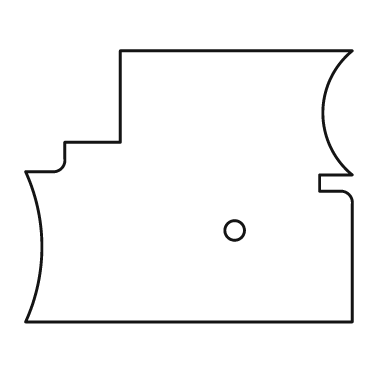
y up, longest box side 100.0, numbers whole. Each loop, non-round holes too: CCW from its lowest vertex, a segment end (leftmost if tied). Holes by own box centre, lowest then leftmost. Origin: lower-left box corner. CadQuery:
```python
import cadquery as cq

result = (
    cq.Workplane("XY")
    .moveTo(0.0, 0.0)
    .lineTo(100.0, 0.0)
    .lineTo(100.0, 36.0)
    .threePointArc((99.0, 39.0), (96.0, 40.0))
    .lineTo(90.0, 40.0)
    .lineTo(90.0, 45.0)
    .lineTo(100.0, 45.0)
    .threePointArc((91.0, 64.0), (100.0, 83.0))
    .lineTo(29.0, 83.0)
    .lineTo(29.0, 55.0)
    .lineTo(12.0, 55.0)
    .lineTo(12.0, 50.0)
    .threePointArc((11.0, 47.0), (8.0, 46.0))
    .lineTo(0.0, 46.0)
    .threePointArc((5.0, 23.0), (0.0, 0.0))
    .close()
    .moveTo(64.0, 28.0)
    .circle(3.0)
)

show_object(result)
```